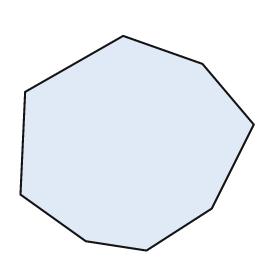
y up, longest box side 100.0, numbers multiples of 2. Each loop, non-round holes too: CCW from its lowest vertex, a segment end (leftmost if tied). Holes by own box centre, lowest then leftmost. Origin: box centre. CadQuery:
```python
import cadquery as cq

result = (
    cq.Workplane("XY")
    .moveTo(4.0, -46.0)
    .lineTo(32.0, -28.0)
    .lineTo(50.0, 8.0)
    .lineTo(28.0, 34.0)
    .lineTo(-6.0, 46.0)
    .lineTo(-48.0, 22.0)
    .lineTo(-50.0, -22.0)
    .lineTo(-22.0, -42.0)
    .close()
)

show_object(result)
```